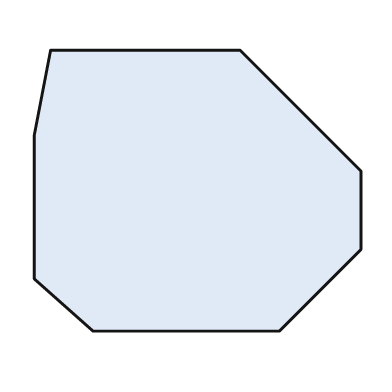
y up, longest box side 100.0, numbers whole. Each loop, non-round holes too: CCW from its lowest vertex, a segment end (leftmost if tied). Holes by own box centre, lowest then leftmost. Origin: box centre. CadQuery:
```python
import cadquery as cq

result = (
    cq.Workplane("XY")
    .moveTo(-32.0, -43.0)
    .lineTo(25.0, -43.0)
    .lineTo(50.0, -18.0)
    .lineTo(50.0, 6.0)
    .lineTo(13.0, 43.0)
    .lineTo(-45.0, 43.0)
    .lineTo(-50.0, 17.0)
    .lineTo(-50.0, -27.0)
    .close()
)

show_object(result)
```